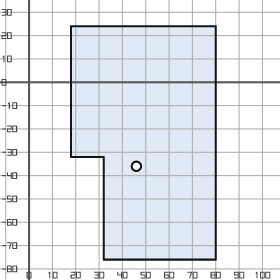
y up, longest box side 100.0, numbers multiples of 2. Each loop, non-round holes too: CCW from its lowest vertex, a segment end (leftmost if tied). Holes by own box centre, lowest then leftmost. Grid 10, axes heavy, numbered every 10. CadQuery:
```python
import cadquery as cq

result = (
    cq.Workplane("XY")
    .moveTo(32.0, -76.0)
    .lineTo(80.0, -76.0)
    .lineTo(80.0, 24.0)
    .lineTo(18.0, 24.0)
    .lineTo(18.0, -32.0)
    .lineTo(32.0, -32.0)
    .close()
    .moveTo(46.0, -36.0)
    .circle(2.0)
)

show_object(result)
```